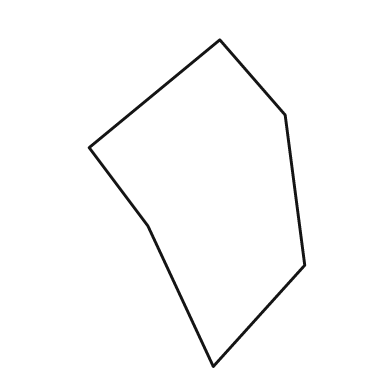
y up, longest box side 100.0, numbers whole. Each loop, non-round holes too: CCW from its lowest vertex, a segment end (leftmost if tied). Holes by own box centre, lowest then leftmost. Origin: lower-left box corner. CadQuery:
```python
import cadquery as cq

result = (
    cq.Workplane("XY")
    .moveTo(38.0, 0.0)
    .lineTo(66.0, 31.0)
    .lineTo(60.0, 77.0)
    .lineTo(40.0, 100.0)
    .lineTo(0.0, 67.0)
    .lineTo(18.0, 43.0)
    .close()
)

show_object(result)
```